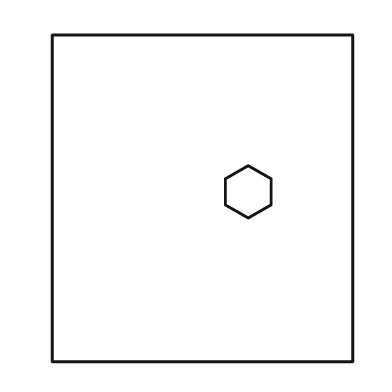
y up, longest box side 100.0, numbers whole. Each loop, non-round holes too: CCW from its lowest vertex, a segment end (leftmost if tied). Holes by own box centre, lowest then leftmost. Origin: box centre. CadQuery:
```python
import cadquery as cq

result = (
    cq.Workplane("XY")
    .moveTo(-46.0, -50.0)
    .lineTo(46.0, -50.0)
    .lineTo(46.0, 50.0)
    .lineTo(-46.0, 50.0)
    .close()
    .moveTo(14.0, -6.0)
    .lineTo(21.0, -2.0)
    .lineTo(21.0, 6.0)
    .lineTo(14.0, 10.0)
    .lineTo(7.0, 6.0)
    .lineTo(7.0, -2.0)
    .close()
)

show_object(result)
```